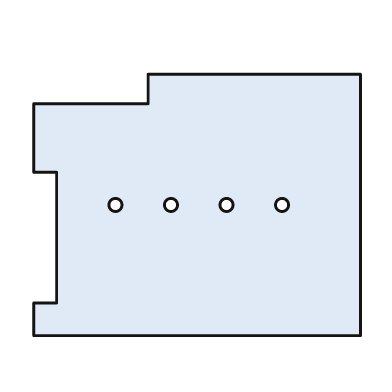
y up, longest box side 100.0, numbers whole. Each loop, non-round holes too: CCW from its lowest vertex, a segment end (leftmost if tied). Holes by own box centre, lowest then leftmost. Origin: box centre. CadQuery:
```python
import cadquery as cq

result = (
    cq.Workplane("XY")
    .moveTo(-50.0, -40.0)
    .lineTo(50.0, -40.0)
    .lineTo(50.0, 40.0)
    .lineTo(-15.0, 40.0)
    .lineTo(-15.0, 31.0)
    .lineTo(-50.0, 31.0)
    .lineTo(-50.0, 10.0)
    .lineTo(-43.0, 10.0)
    .lineTo(-43.0, -30.0)
    .lineTo(-50.0, -30.0)
    .close()
    .moveTo(-25.0, 0.0)
    .circle(2.0)
    .moveTo(-8.0, 0.0)
    .circle(2.0)
    .moveTo(9.0, 0.0)
    .circle(2.0)
    .moveTo(26.0, 0.0)
    .circle(2.0)
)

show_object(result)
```